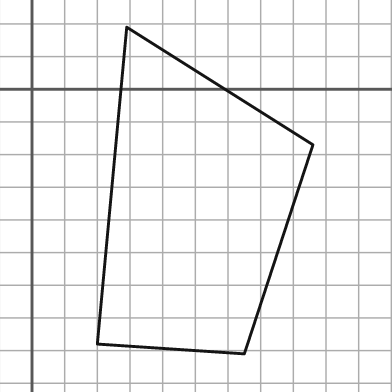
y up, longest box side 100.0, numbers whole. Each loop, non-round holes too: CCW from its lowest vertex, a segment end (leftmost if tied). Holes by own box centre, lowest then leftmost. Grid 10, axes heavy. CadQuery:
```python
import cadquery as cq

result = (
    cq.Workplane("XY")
    .moveTo(65.0, -81.0)
    .lineTo(86.0, -17.0)
    .lineTo(29.0, 19.0)
    .lineTo(20.0, -78.0)
    .close()
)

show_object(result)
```